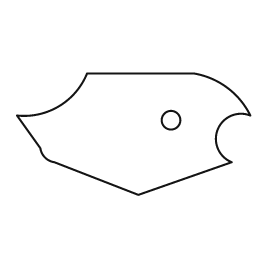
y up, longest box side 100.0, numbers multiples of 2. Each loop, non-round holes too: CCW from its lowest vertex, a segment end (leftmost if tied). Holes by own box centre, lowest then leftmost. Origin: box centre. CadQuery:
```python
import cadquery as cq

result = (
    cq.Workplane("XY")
    .moveTo(2.0, -26.0)
    .lineTo(42.0, -12.0)
    .threePointArc((36.0, 2.0), (50.0, 8.0))
    .threePointArc((40.0, 20.0), (26.0, 26.0))
    .lineTo(-20.0, 26.0)
    .threePointArc((-32.0, 12.0), (-50.0, 8.0))
    .lineTo(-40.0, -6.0)
    .threePointArc((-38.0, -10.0), (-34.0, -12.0))
    .close()
    .moveTo(16.0, 6.0)
    .circle(4.0)
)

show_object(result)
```